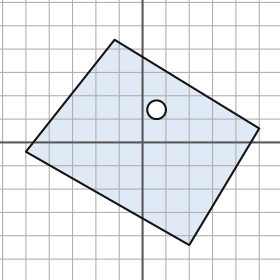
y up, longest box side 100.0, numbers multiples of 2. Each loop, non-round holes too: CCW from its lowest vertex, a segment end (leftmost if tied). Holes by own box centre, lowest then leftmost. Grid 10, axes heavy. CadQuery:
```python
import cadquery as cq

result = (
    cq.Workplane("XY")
    .moveTo(20.0, -44.0)
    .lineTo(50.0, 6.0)
    .lineTo(-12.0, 44.0)
    .lineTo(-50.0, -4.0)
    .close()
    .moveTo(6.0, 14.0)
    .circle(4.0)
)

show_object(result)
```